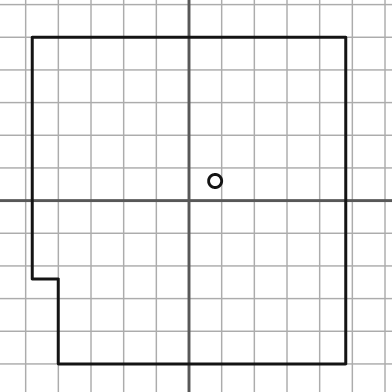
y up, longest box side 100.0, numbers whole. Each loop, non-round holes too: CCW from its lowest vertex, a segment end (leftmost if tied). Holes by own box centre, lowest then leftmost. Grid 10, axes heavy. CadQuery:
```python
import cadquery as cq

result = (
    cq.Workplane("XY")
    .moveTo(-40.0, -50.0)
    .lineTo(48.0, -50.0)
    .lineTo(48.0, 50.0)
    .lineTo(-48.0, 50.0)
    .lineTo(-48.0, -24.0)
    .lineTo(-40.0, -24.0)
    .close()
    .moveTo(8.0, 6.0)
    .circle(2.0)
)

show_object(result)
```